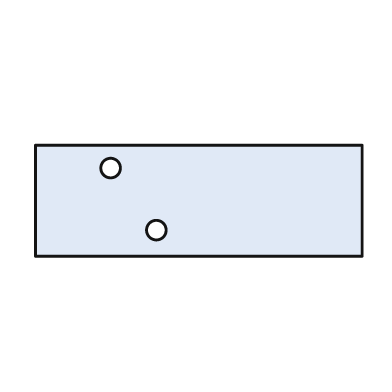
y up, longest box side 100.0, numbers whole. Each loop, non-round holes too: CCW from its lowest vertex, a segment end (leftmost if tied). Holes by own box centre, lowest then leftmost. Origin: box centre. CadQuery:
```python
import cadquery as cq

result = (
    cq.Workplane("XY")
    .moveTo(-50.0, -17.0)
    .lineTo(50.0, -17.0)
    .lineTo(50.0, 17.0)
    .lineTo(-50.0, 17.0)
    .close()
    .moveTo(-13.0, -9.0)
    .circle(3.0)
    .moveTo(-27.0, 10.0)
    .circle(3.0)
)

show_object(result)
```